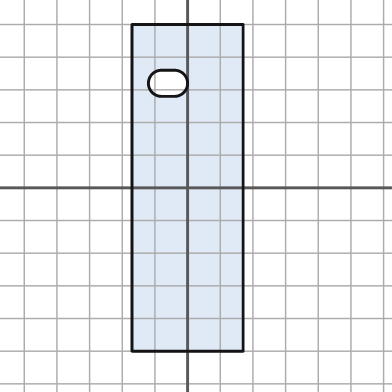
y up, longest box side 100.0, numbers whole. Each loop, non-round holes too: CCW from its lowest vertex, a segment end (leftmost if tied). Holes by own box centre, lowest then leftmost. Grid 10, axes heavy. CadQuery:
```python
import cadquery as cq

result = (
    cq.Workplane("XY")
    .moveTo(-17.0, -50.0)
    .lineTo(17.0, -50.0)
    .lineTo(17.0, 50.0)
    .lineTo(-17.0, 50.0)
    .close()
    .moveTo(-8.0, 28.0)
    .lineTo(-4.0, 28.0)
    .threePointArc((0.0, 32.0), (-4.0, 36.0))
    .lineTo(-8.0, 36.0)
    .threePointArc((-12.0, 32.0), (-8.0, 28.0))
    .close()
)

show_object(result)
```